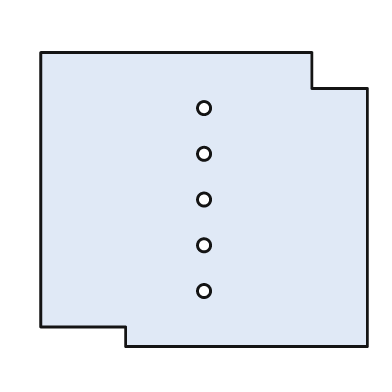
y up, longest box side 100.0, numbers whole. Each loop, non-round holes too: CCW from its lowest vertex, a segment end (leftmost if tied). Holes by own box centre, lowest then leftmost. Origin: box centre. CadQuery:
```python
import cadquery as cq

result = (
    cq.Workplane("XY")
    .moveTo(-24.0, -45.0)
    .lineTo(50.0, -45.0)
    .lineTo(50.0, 34.0)
    .lineTo(33.0, 34.0)
    .lineTo(33.0, 45.0)
    .lineTo(-50.0, 45.0)
    .lineTo(-50.0, -39.0)
    .lineTo(-24.0, -39.0)
    .close()
    .moveTo(0.0, -28.0)
    .circle(2.0)
    .moveTo(0.0, -14.0)
    .circle(2.0)
    .moveTo(0.0, 0.0)
    .circle(2.0)
    .moveTo(0.0, 14.0)
    .circle(2.0)
    .moveTo(0.0, 28.0)
    .circle(2.0)
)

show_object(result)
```